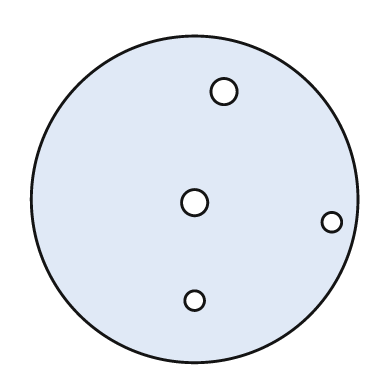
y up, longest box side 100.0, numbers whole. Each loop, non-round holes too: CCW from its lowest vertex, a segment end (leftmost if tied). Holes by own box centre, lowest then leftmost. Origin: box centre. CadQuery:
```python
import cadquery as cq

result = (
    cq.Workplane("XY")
    .moveTo(0.0, 0.0)
    .circle(50.0)
    .moveTo(0.0, -31.0)
    .circle(3.0)
    .moveTo(42.0, -7.0)
    .circle(3.0)
    .moveTo(0.0, -1.0)
    .circle(4.0)
    .moveTo(9.0, 33.0)
    .circle(4.0)
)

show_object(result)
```